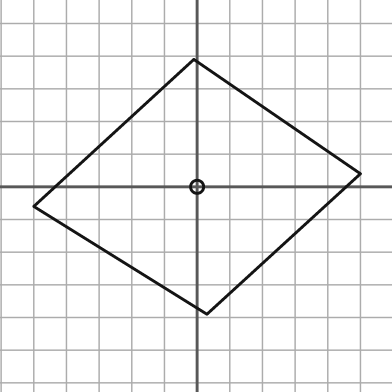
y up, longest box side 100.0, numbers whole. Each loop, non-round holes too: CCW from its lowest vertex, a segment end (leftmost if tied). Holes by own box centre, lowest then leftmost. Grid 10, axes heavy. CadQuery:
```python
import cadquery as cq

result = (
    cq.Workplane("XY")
    .moveTo(3.0, -39.0)
    .lineTo(50.0, 4.0)
    .lineTo(-1.0, 39.0)
    .lineTo(-50.0, -6.0)
    .close()
    .moveTo(0.0, 0.0)
    .circle(2.0)
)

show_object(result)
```